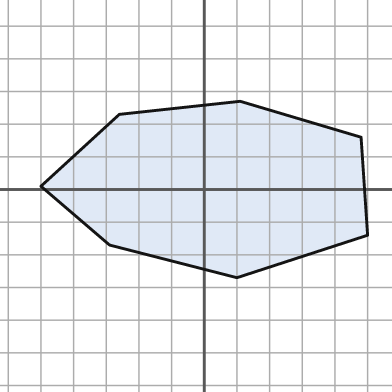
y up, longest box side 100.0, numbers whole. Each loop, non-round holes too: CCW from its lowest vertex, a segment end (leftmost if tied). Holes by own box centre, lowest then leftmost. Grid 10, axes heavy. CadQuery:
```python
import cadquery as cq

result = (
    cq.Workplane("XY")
    .moveTo(10.0, -27.0)
    .lineTo(50.0, -14.0)
    .lineTo(48.0, 16.0)
    .lineTo(11.0, 27.0)
    .lineTo(-26.0, 23.0)
    .lineTo(-50.0, 1.0)
    .lineTo(-29.0, -17.0)
    .close()
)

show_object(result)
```